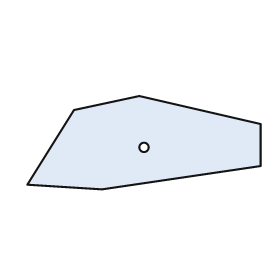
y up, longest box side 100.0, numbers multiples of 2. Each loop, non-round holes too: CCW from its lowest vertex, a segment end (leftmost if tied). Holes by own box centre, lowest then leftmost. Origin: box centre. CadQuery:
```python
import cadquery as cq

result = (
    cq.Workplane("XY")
    .moveTo(-18.0, -20.0)
    .lineTo(50.0, -10.0)
    .lineTo(50.0, 8.0)
    .lineTo(-2.0, 20.0)
    .lineTo(-30.0, 14.0)
    .lineTo(-50.0, -18.0)
    .close()
    .moveTo(0.0, -2.0)
    .circle(2.0)
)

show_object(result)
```